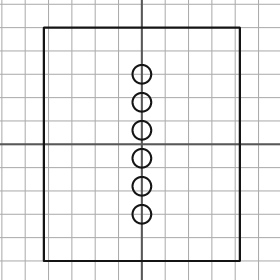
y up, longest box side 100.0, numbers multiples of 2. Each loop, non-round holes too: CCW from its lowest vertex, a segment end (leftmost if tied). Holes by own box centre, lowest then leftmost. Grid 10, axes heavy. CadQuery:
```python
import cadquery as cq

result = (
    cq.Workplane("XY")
    .moveTo(-42.0, -50.0)
    .lineTo(42.0, -50.0)
    .lineTo(42.0, 50.0)
    .lineTo(-42.0, 50.0)
    .close()
    .moveTo(0.0, -30.0)
    .circle(4.0)
    .moveTo(0.0, -18.0)
    .circle(4.0)
    .moveTo(0.0, -6.0)
    .circle(4.0)
    .moveTo(0.0, 6.0)
    .circle(4.0)
    .moveTo(0.0, 18.0)
    .circle(4.0)
    .moveTo(0.0, 30.0)
    .circle(4.0)
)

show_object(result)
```